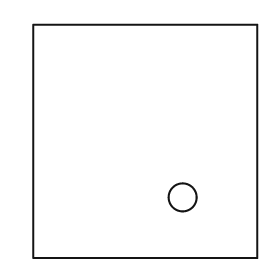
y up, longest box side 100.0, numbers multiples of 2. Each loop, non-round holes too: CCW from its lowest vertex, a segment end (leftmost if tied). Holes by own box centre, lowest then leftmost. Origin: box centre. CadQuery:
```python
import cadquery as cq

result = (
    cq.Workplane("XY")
    .moveTo(-48.0, -50.0)
    .lineTo(48.0, -50.0)
    .lineTo(48.0, 50.0)
    .lineTo(-48.0, 50.0)
    .close()
    .moveTo(16.0, -24.0)
    .circle(6.0)
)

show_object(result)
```